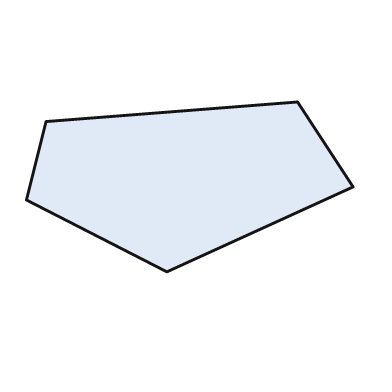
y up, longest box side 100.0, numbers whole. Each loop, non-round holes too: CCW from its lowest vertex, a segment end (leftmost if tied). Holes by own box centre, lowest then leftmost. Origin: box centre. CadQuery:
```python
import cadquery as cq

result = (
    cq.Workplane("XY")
    .moveTo(-7.0, -26.0)
    .lineTo(50.0, 0.0)
    .lineTo(33.0, 26.0)
    .lineTo(-44.0, 20.0)
    .lineTo(-50.0, -4.0)
    .close()
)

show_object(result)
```